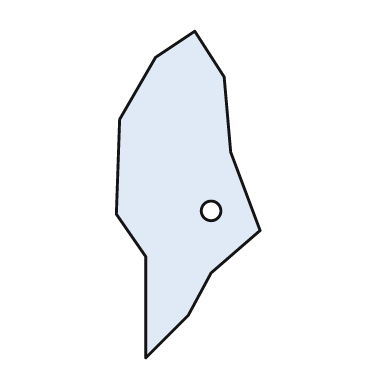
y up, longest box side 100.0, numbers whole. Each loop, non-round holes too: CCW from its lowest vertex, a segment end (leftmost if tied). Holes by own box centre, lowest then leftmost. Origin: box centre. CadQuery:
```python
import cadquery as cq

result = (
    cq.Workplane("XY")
    .moveTo(-13.0, -50.0)
    .lineTo(0.0, -37.0)
    .lineTo(7.0, -24.0)
    .lineTo(22.0, -11.0)
    .lineTo(13.0, 13.0)
    .lineTo(11.0, 36.0)
    .lineTo(2.0, 50.0)
    .lineTo(-10.0, 42.0)
    .lineTo(-21.0, 23.0)
    .lineTo(-22.0, -6.0)
    .lineTo(-13.0, -19.0)
    .close()
    .moveTo(7.0, -5.0)
    .circle(3.0)
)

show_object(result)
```